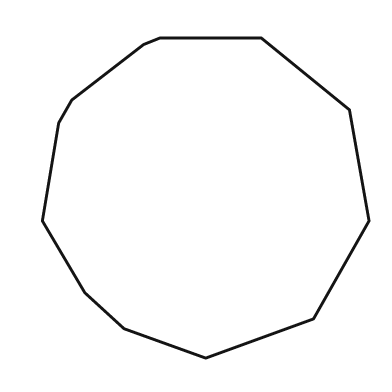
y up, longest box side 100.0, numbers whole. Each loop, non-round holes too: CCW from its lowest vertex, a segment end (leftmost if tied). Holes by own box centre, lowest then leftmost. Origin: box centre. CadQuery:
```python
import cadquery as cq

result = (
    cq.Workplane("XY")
    .moveTo(0.0, -49.0)
    .lineTo(33.0, -37.0)
    .lineTo(50.0, -7.0)
    .lineTo(44.0, 27.0)
    .lineTo(17.0, 49.0)
    .lineTo(-14.0, 49.0)
    .lineTo(-19.0, 47.0)
    .lineTo(-41.0, 30.0)
    .lineTo(-45.0, 23.0)
    .lineTo(-50.0, -7.0)
    .lineTo(-37.0, -29.0)
    .lineTo(-25.0, -40.0)
    .close()
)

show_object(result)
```